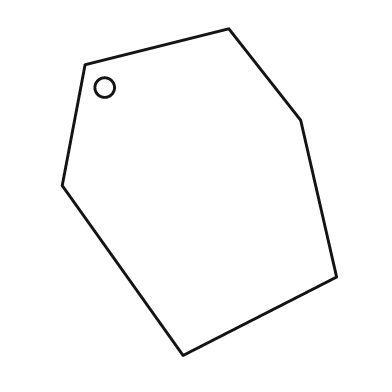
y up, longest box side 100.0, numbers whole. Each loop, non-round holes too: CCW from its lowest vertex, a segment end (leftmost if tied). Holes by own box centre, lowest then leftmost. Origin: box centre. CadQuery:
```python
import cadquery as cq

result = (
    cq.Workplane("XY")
    .moveTo(-5.0, -50.0)
    .lineTo(42.0, -26.0)
    .lineTo(31.0, 22.0)
    .lineTo(9.0, 50.0)
    .lineTo(-35.0, 39.0)
    .lineTo(-42.0, 2.0)
    .close()
    .moveTo(-29.0, 32.0)
    .circle(3.0)
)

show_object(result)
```